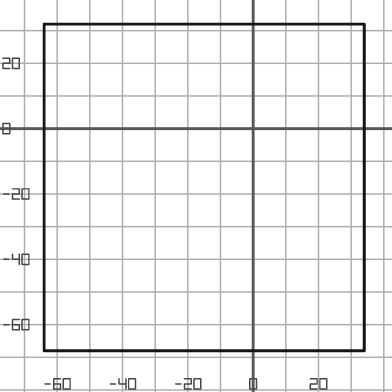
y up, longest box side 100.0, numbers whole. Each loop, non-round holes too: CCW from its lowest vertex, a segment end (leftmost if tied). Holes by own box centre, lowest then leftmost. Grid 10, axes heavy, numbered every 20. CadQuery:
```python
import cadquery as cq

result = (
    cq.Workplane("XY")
    .moveTo(-64.0, -68.0)
    .lineTo(34.0, -68.0)
    .lineTo(34.0, 32.0)
    .lineTo(-64.0, 32.0)
    .close()
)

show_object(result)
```